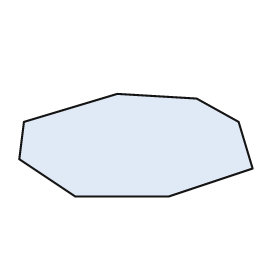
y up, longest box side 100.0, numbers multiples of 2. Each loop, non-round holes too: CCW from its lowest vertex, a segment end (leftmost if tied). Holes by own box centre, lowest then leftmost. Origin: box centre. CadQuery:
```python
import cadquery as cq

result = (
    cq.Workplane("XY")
    .moveTo(-26.0, -22.0)
    .lineTo(14.0, -22.0)
    .lineTo(50.0, -10.0)
    .lineTo(44.0, 10.0)
    .lineTo(26.0, 20.0)
    .lineTo(-8.0, 22.0)
    .lineTo(-48.0, 10.0)
    .lineTo(-50.0, -6.0)
    .close()
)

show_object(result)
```